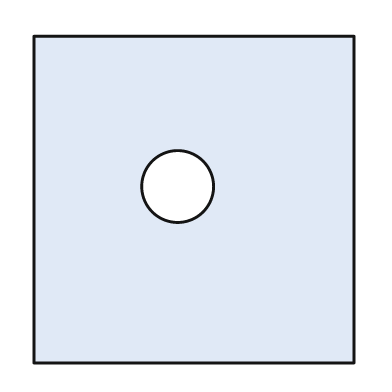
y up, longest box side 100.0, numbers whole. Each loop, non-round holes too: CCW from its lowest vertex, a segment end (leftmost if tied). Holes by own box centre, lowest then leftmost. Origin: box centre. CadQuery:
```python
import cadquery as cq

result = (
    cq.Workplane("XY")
    .moveTo(-49.0, -50.0)
    .lineTo(49.0, -50.0)
    .lineTo(49.0, 50.0)
    .lineTo(-49.0, 50.0)
    .close()
    .moveTo(-5.0, 4.0)
    .circle(11.0)
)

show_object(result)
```